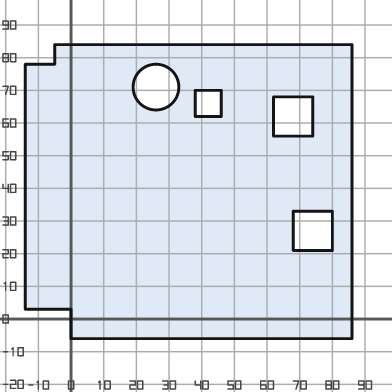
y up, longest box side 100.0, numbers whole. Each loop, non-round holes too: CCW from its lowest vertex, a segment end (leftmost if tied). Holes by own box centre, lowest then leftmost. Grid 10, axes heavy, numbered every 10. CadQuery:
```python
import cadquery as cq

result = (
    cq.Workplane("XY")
    .moveTo(0.0, -6.0)
    .lineTo(86.0, -6.0)
    .lineTo(86.0, 84.0)
    .lineTo(-5.0, 84.0)
    .lineTo(-5.0, 78.0)
    .lineTo(-14.0, 78.0)
    .lineTo(-14.0, 3.0)
    .lineTo(0.0, 3.0)
    .close()
    .moveTo(68.0, 21.0)
    .lineTo(80.0, 21.0)
    .lineTo(80.0, 33.0)
    .lineTo(68.0, 33.0)
    .close()
    .moveTo(62.0, 56.0)
    .lineTo(74.0, 56.0)
    .lineTo(74.0, 68.0)
    .lineTo(62.0, 68.0)
    .close()
    .moveTo(38.0, 62.0)
    .lineTo(46.0, 62.0)
    .lineTo(46.0, 70.0)
    .lineTo(38.0, 70.0)
    .close()
    .moveTo(26.0, 71.0)
    .circle(7.0)
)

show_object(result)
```